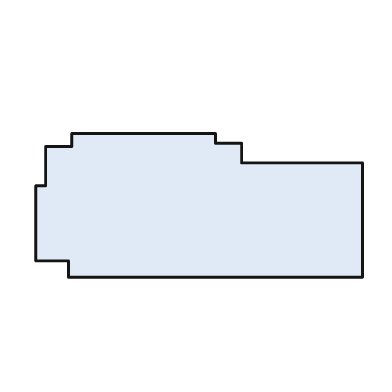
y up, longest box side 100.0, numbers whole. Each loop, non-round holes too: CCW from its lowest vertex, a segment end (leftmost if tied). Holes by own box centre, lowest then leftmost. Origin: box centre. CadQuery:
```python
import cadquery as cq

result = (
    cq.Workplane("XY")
    .moveTo(-40.0, -22.0)
    .lineTo(50.0, -22.0)
    .lineTo(50.0, 13.0)
    .lineTo(13.0, 13.0)
    .lineTo(13.0, 19.0)
    .lineTo(5.0, 19.0)
    .lineTo(5.0, 22.0)
    .lineTo(-39.0, 22.0)
    .lineTo(-39.0, 18.0)
    .lineTo(-47.0, 18.0)
    .lineTo(-47.0, 6.0)
    .lineTo(-50.0, 6.0)
    .lineTo(-50.0, -17.0)
    .lineTo(-40.0, -17.0)
    .close()
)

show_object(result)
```